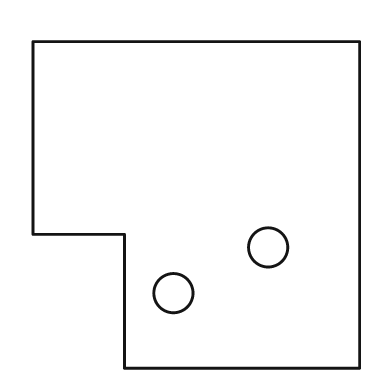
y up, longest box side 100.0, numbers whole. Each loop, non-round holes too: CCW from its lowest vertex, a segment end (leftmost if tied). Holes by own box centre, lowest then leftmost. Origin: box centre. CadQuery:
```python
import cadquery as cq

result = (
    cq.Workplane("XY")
    .moveTo(-22.0, -50.0)
    .lineTo(50.0, -50.0)
    .lineTo(50.0, 50.0)
    .lineTo(-50.0, 50.0)
    .lineTo(-50.0, -9.0)
    .lineTo(-22.0, -9.0)
    .close()
    .moveTo(-7.0, -27.0)
    .circle(6.0)
    .moveTo(22.0, -13.0)
    .circle(6.0)
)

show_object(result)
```